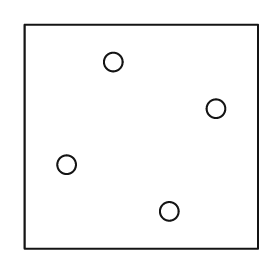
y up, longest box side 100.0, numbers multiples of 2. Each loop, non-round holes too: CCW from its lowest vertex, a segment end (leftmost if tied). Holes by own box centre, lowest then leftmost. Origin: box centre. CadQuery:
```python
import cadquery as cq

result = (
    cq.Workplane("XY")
    .moveTo(-50.0, -48.0)
    .lineTo(50.0, -48.0)
    .lineTo(50.0, 48.0)
    .lineTo(-50.0, 48.0)
    .close()
    .moveTo(12.0, -32.0)
    .circle(4.0)
    .moveTo(-32.0, -12.0)
    .circle(4.0)
    .moveTo(32.0, 12.0)
    .circle(4.0)
    .moveTo(-12.0, 32.0)
    .circle(4.0)
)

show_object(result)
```